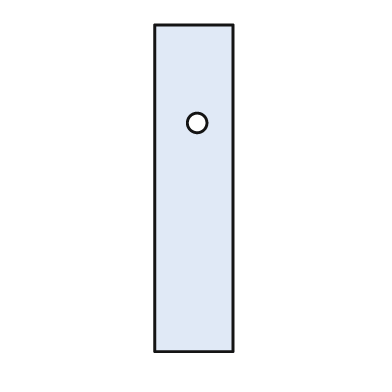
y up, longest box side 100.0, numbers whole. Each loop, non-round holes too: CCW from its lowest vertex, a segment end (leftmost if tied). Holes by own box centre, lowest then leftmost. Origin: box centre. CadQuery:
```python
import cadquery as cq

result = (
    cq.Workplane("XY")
    .moveTo(-12.0, -50.0)
    .lineTo(12.0, -50.0)
    .lineTo(12.0, 50.0)
    .lineTo(-12.0, 50.0)
    .close()
    .moveTo(1.0, 20.0)
    .circle(3.0)
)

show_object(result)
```